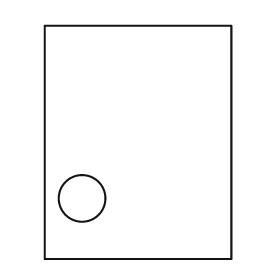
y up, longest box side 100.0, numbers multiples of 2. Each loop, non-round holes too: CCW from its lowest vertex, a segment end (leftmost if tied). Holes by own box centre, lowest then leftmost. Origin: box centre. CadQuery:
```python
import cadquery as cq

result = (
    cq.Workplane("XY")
    .moveTo(-40.0, -50.0)
    .lineTo(40.0, -50.0)
    .lineTo(40.0, 50.0)
    .lineTo(-40.0, 50.0)
    .close()
    .moveTo(-24.0, -24.0)
    .circle(10.0)
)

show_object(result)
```